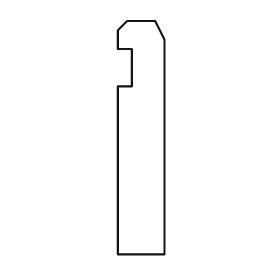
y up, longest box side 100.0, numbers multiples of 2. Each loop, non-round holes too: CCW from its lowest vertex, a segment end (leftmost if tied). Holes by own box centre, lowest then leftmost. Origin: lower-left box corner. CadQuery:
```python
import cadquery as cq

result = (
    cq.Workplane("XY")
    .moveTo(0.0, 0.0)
    .lineTo(20.0, 0.0)
    .lineTo(20.0, 92.0)
    .lineTo(16.0, 100.0)
    .lineTo(4.0, 100.0)
    .lineTo(0.0, 96.0)
    .lineTo(0.0, 88.0)
    .lineTo(6.0, 88.0)
    .lineTo(6.0, 72.0)
    .lineTo(0.0, 72.0)
    .close()
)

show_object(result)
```